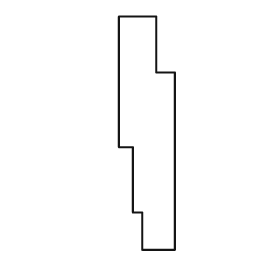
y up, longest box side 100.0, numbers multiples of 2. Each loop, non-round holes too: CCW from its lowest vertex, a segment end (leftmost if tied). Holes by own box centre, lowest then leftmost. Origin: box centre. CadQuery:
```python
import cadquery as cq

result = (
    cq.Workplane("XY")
    .moveTo(-2.0, -50.0)
    .lineTo(12.0, -50.0)
    .lineTo(12.0, 26.0)
    .lineTo(4.0, 26.0)
    .lineTo(4.0, 50.0)
    .lineTo(-12.0, 50.0)
    .lineTo(-12.0, -6.0)
    .lineTo(-6.0, -6.0)
    .lineTo(-6.0, -34.0)
    .lineTo(-2.0, -34.0)
    .close()
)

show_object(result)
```